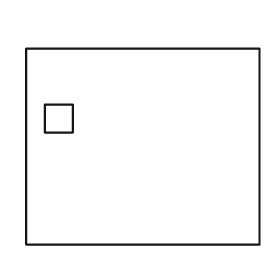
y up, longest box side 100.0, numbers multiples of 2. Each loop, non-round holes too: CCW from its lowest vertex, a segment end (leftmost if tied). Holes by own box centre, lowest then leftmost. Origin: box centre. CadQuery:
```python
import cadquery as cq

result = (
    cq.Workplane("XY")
    .moveTo(-50.0, -42.0)
    .lineTo(50.0, -42.0)
    .lineTo(50.0, 42.0)
    .lineTo(-50.0, 42.0)
    .close()
    .moveTo(-42.0, 6.0)
    .lineTo(-30.0, 6.0)
    .lineTo(-30.0, 18.0)
    .lineTo(-42.0, 18.0)
    .close()
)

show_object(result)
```